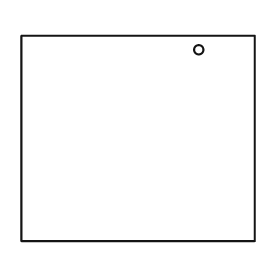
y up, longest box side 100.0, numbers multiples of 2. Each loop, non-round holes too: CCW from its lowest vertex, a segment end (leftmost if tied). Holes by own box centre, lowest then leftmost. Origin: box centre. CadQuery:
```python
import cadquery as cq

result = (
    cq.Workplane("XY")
    .moveTo(-50.0, -44.0)
    .lineTo(50.0, -44.0)
    .lineTo(50.0, 44.0)
    .lineTo(-50.0, 44.0)
    .close()
    .moveTo(26.0, 38.0)
    .circle(2.0)
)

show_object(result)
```